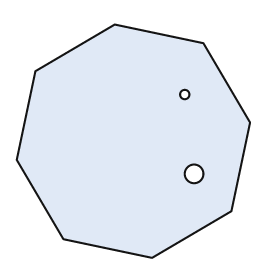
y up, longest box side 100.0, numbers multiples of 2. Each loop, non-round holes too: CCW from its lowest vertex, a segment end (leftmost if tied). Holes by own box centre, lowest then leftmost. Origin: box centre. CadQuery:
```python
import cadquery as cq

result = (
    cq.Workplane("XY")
    .moveTo(8.0, -50.0)
    .lineTo(42.0, -30.0)
    .lineTo(50.0, 8.0)
    .lineTo(30.0, 42.0)
    .lineTo(-8.0, 50.0)
    .lineTo(-42.0, 30.0)
    .lineTo(-50.0, -8.0)
    .lineTo(-30.0, -42.0)
    .close()
    .moveTo(26.0, -14.0)
    .circle(4.0)
    .moveTo(22.0, 20.0)
    .circle(2.0)
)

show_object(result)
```